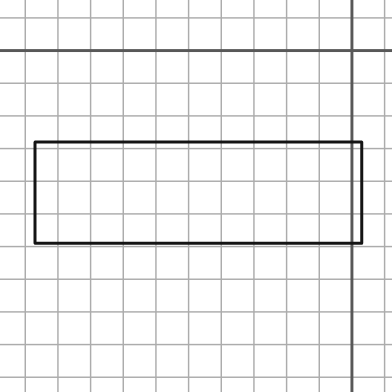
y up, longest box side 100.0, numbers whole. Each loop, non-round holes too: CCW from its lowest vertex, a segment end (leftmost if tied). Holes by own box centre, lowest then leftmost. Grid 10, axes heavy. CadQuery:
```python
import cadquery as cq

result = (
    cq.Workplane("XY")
    .moveTo(-97.0, -59.0)
    .lineTo(3.0, -59.0)
    .lineTo(3.0, -28.0)
    .lineTo(-97.0, -28.0)
    .close()
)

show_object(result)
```